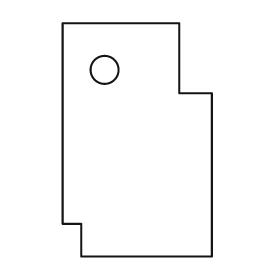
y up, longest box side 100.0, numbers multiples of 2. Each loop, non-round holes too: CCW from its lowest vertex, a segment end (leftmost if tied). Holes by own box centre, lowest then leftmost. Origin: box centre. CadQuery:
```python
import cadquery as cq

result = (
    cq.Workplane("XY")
    .moveTo(-24.0, -50.0)
    .lineTo(32.0, -50.0)
    .lineTo(32.0, 20.0)
    .lineTo(18.0, 20.0)
    .lineTo(18.0, 50.0)
    .lineTo(-32.0, 50.0)
    .lineTo(-32.0, -36.0)
    .lineTo(-24.0, -36.0)
    .close()
    .moveTo(-14.0, 30.0)
    .circle(6.0)
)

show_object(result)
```